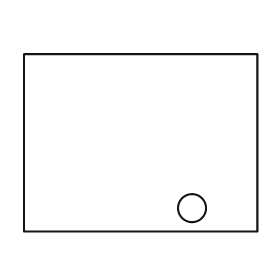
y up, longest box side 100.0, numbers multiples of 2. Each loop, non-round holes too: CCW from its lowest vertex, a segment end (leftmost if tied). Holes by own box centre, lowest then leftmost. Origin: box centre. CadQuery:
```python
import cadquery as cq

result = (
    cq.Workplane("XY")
    .moveTo(-50.0, -38.0)
    .lineTo(50.0, -38.0)
    .lineTo(50.0, 38.0)
    .lineTo(-50.0, 38.0)
    .close()
    .moveTo(22.0, -28.0)
    .circle(6.0)
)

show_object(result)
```